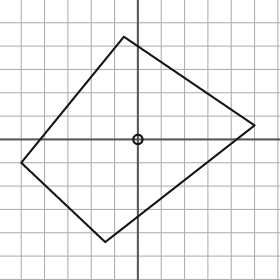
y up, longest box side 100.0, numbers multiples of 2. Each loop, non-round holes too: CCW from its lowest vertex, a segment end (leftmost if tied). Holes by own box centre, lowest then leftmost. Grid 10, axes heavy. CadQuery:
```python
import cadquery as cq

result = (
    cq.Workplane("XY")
    .moveTo(-14.0, -44.0)
    .lineTo(50.0, 6.0)
    .lineTo(-6.0, 44.0)
    .lineTo(-50.0, -10.0)
    .close()
    .moveTo(0.0, 0.0)
    .circle(2.0)
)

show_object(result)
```